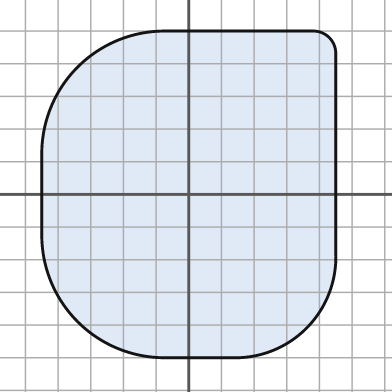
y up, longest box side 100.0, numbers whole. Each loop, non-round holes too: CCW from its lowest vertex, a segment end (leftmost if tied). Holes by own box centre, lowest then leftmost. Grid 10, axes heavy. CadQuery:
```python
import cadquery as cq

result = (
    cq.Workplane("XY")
    .moveTo(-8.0, -50.0)
    .lineTo(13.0, -50.0)
    .threePointArc((36.0, -41.0), (45.0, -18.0))
    .lineTo(45.0, 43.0)
    .threePointArc((43.0, 48.0), (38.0, 50.0))
    .lineTo(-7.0, 50.0)
    .threePointArc((-34.0, 39.0), (-45.0, 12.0))
    .lineTo(-45.0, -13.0)
    .threePointArc((-34.0, -39.0), (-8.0, -50.0))
    .close()
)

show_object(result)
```